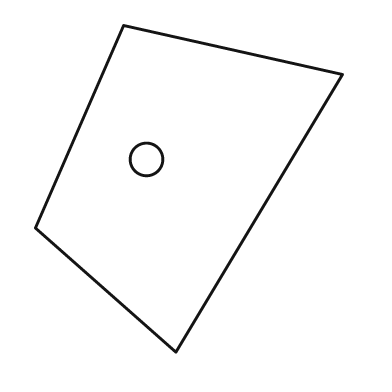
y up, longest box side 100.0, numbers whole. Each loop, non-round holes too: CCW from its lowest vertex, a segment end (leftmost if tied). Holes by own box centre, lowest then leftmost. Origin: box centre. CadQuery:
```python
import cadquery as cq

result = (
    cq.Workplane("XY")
    .moveTo(-4.0, -50.0)
    .lineTo(47.0, 35.0)
    .lineTo(-20.0, 50.0)
    .lineTo(-47.0, -12.0)
    .close()
    .moveTo(-13.0, 9.0)
    .circle(5.0)
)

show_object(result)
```